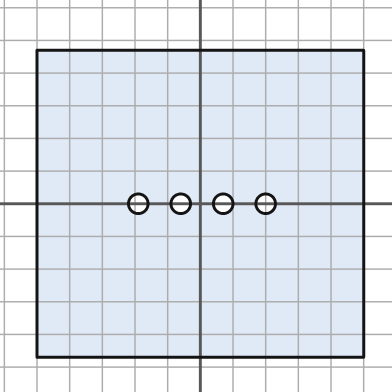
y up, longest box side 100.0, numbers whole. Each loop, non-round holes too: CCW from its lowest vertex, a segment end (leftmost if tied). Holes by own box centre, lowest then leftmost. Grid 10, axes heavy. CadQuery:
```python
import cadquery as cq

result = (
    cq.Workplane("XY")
    .moveTo(-50.0, -47.0)
    .lineTo(50.0, -47.0)
    .lineTo(50.0, 47.0)
    .lineTo(-50.0, 47.0)
    .close()
    .moveTo(-19.0, 0.0)
    .circle(3.0)
    .moveTo(-6.0, 0.0)
    .circle(3.0)
    .moveTo(7.0, 0.0)
    .circle(3.0)
    .moveTo(20.0, 0.0)
    .circle(3.0)
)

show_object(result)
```